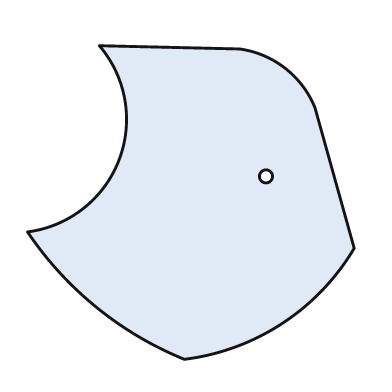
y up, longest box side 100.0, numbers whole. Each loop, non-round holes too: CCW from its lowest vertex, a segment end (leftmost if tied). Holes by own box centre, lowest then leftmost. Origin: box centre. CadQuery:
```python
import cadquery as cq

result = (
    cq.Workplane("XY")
    .moveTo(-2.0, -48.0)
    .threePointArc((28.0, -37.0), (50.0, -14.0))
    .lineTo(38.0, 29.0)
    .threePointArc((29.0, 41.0), (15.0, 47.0))
    .lineTo(-28.0, 48.0)
    .threePointArc((-22.0, 13.0), (-50.0, -9.0))
    .threePointArc((-29.0, -32.0), (-2.0, -48.0))
    .close()
    .moveTo(23.0, 8.0)
    .circle(2.0)
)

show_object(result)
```